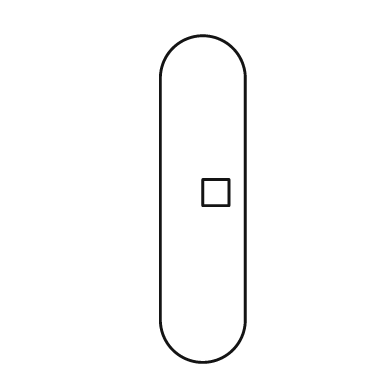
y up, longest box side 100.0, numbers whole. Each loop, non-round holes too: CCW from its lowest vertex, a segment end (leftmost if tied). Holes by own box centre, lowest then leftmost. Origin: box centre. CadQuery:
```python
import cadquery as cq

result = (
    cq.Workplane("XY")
    .moveTo(-13.0, -37.0)
    .threePointArc((0.0, -50.0), (13.0, -37.0))
    .lineTo(13.0, 37.0)
    .threePointArc((0.0, 50.0), (-13.0, 37.0))
    .close()
    .moveTo(0.0, -2.0)
    .lineTo(8.0, -2.0)
    .lineTo(8.0, 6.0)
    .lineTo(0.0, 6.0)
    .close()
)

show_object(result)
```